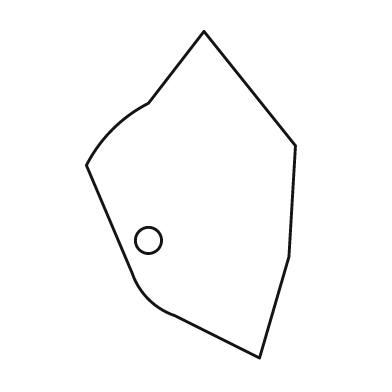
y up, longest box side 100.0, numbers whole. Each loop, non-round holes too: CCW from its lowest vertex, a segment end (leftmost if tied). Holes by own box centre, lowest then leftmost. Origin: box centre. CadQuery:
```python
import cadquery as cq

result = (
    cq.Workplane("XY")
    .moveTo(21.0, -50.0)
    .lineTo(30.0, -19.0)
    .lineTo(32.0, 15.0)
    .lineTo(4.0, 50.0)
    .lineTo(-13.0, 28.0)
    .threePointArc((-24.0, 20.0), (-32.0, 9.0))
    .lineTo(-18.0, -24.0)
    .threePointArc((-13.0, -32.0), (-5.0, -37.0))
    .close()
    .moveTo(-13.0, -14.0)
    .circle(4.0)
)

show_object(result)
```